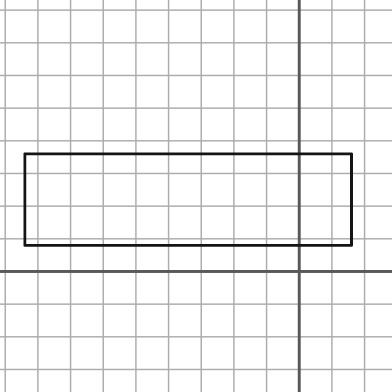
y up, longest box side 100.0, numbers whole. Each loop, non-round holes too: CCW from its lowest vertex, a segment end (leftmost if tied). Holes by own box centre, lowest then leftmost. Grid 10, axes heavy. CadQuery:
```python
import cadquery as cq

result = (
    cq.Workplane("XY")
    .moveTo(-84.0, 8.0)
    .lineTo(16.0, 8.0)
    .lineTo(16.0, 36.0)
    .lineTo(-84.0, 36.0)
    .close()
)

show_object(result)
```